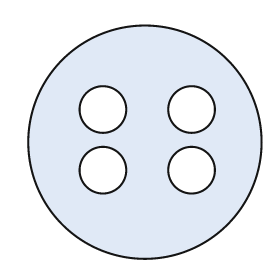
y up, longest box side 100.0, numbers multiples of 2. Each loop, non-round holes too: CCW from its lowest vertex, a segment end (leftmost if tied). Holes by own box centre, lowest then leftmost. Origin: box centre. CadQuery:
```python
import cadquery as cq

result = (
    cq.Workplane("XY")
    .moveTo(0.0, 0.0)
    .circle(50.0)
    .moveTo(-18.0, -12.0)
    .circle(10.0)
    .moveTo(20.0, -12.0)
    .circle(10.0)
    .moveTo(-18.0, 14.0)
    .circle(10.0)
    .moveTo(20.0, 14.0)
    .circle(10.0)
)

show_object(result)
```